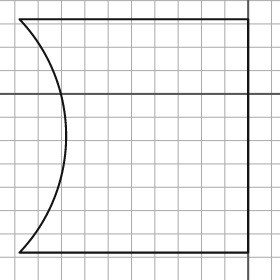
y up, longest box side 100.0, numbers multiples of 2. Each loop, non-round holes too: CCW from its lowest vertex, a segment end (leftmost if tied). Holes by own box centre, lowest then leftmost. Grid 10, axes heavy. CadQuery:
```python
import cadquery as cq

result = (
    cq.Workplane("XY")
    .moveTo(-98.0, -68.0)
    .lineTo(0.0, -68.0)
    .lineTo(0.0, 32.0)
    .lineTo(-98.0, 32.0)
    .threePointArc((-78.0, -18.0), (-98.0, -68.0))
    .close()
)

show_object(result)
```